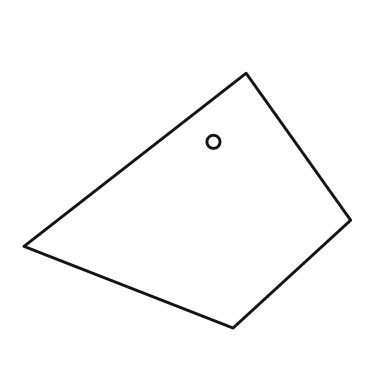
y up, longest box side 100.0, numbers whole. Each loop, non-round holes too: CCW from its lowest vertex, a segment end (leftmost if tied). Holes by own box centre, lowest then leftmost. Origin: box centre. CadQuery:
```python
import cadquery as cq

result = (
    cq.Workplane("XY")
    .moveTo(14.0, -39.0)
    .lineTo(50.0, -6.0)
    .lineTo(18.0, 39.0)
    .lineTo(-50.0, -14.0)
    .close()
    .moveTo(8.0, 18.0)
    .circle(2.0)
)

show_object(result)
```